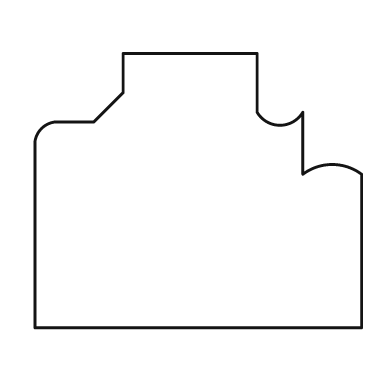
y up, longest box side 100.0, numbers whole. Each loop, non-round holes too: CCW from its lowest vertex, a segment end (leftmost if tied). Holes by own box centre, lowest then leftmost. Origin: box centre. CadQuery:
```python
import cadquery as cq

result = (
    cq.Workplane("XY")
    .moveTo(-50.0, -42.0)
    .lineTo(50.0, -42.0)
    .lineTo(50.0, 5.0)
    .threePointArc((41.0, 8.0), (32.0, 5.0))
    .lineTo(32.0, 24.0)
    .threePointArc((25.0, 20.0), (18.0, 24.0))
    .lineTo(18.0, 42.0)
    .lineTo(-23.0, 42.0)
    .lineTo(-23.0, 30.0)
    .lineTo(-32.0, 21.0)
    .lineTo(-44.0, 21.0)
    .threePointArc((-48.0, 19.0), (-50.0, 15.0))
    .close()
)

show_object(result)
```